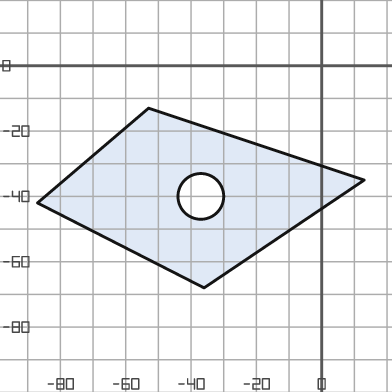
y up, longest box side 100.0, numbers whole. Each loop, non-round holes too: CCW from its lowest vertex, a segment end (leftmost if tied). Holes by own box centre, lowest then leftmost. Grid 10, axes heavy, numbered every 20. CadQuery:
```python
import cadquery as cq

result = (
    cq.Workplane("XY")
    .moveTo(-36.0, -68.0)
    .lineTo(13.0, -35.0)
    .lineTo(-53.0, -13.0)
    .lineTo(-87.0, -42.0)
    .close()
    .moveTo(-37.0, -40.0)
    .circle(7.0)
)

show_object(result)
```